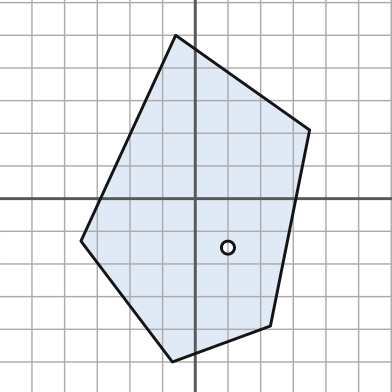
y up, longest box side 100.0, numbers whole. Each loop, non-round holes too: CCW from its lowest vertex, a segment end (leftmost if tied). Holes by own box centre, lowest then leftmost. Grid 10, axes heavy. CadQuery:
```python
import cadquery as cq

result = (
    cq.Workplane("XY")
    .moveTo(-7.0, -50.0)
    .lineTo(23.0, -39.0)
    .lineTo(35.0, 21.0)
    .lineTo(-6.0, 50.0)
    .lineTo(-35.0, -13.0)
    .close()
    .moveTo(10.0, -15.0)
    .circle(2.0)
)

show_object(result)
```